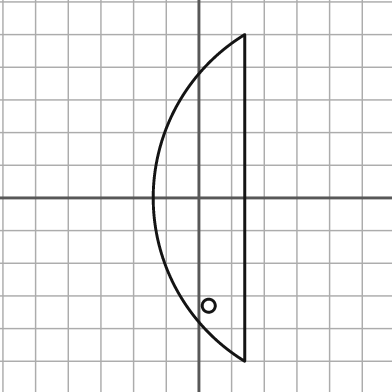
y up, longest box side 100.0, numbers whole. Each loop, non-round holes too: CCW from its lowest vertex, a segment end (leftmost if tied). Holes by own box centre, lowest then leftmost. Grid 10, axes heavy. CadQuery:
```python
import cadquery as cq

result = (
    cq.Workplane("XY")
    .moveTo(14.0, -50.0)
    .lineTo(14.0, 50.0)
    .threePointArc((-14.0, 0.0), (14.0, -50.0))
    .close()
    .moveTo(3.0, -33.0)
    .circle(2.0)
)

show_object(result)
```